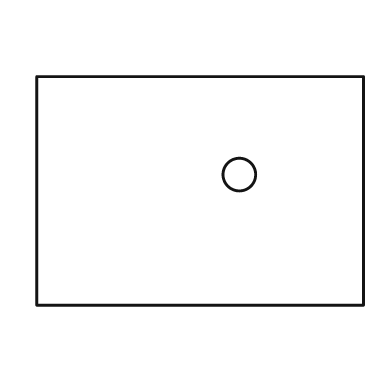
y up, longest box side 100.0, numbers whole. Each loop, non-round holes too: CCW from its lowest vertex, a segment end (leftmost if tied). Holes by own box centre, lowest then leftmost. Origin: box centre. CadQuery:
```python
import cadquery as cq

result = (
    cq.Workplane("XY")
    .moveTo(-50.0, -35.0)
    .lineTo(50.0, -35.0)
    .lineTo(50.0, 35.0)
    .lineTo(-50.0, 35.0)
    .close()
    .moveTo(12.0, 5.0)
    .circle(5.0)
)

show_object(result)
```